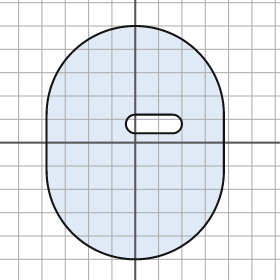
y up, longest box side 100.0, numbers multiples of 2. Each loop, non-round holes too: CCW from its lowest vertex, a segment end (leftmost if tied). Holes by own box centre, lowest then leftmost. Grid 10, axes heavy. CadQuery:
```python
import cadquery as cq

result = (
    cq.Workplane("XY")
    .moveTo(-38.0, -12.0)
    .threePointArc((0.0, -50.0), (38.0, -12.0))
    .lineTo(38.0, 12.0)
    .threePointArc((0.0, 50.0), (-38.0, 12.0))
    .close()
    .moveTo(0.0, 4.0)
    .lineTo(16.0, 4.0)
    .threePointArc((20.0, 8.0), (16.0, 12.0))
    .lineTo(0.0, 12.0)
    .threePointArc((-4.0, 8.0), (0.0, 4.0))
    .close()
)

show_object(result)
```